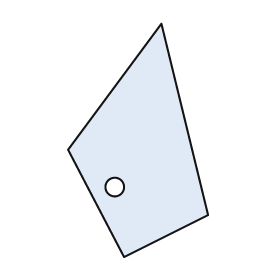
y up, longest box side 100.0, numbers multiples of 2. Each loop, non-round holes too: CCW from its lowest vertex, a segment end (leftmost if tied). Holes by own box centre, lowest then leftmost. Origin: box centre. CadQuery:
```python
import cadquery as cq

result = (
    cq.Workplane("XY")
    .moveTo(-6.0, -50.0)
    .lineTo(30.0, -32.0)
    .lineTo(10.0, 50.0)
    .lineTo(-30.0, -4.0)
    .close()
    .moveTo(-10.0, -20.0)
    .circle(4.0)
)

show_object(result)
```